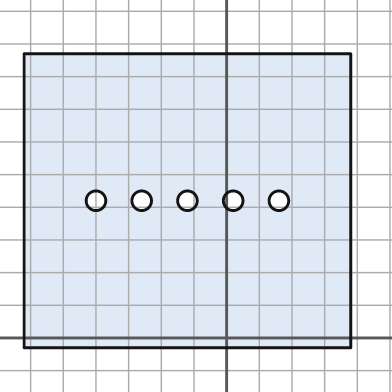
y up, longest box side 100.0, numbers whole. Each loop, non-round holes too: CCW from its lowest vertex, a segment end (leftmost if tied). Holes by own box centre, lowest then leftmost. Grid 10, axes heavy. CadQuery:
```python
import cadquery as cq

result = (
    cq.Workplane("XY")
    .moveTo(-62.0, -3.0)
    .lineTo(38.0, -3.0)
    .lineTo(38.0, 87.0)
    .lineTo(-62.0, 87.0)
    .close()
    .moveTo(-40.0, 42.0)
    .circle(3.0)
    .moveTo(-26.0, 42.0)
    .circle(3.0)
    .moveTo(-12.0, 42.0)
    .circle(3.0)
    .moveTo(2.0, 42.0)
    .circle(3.0)
    .moveTo(16.0, 42.0)
    .circle(3.0)
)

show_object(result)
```